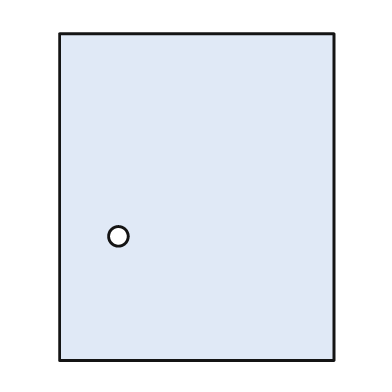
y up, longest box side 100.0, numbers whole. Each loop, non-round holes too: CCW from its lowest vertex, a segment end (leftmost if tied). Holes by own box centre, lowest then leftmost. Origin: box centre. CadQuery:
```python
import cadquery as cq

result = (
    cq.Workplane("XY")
    .moveTo(-42.0, -50.0)
    .lineTo(42.0, -50.0)
    .lineTo(42.0, 50.0)
    .lineTo(-42.0, 50.0)
    .close()
    .moveTo(-24.0, -12.0)
    .circle(3.0)
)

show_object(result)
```